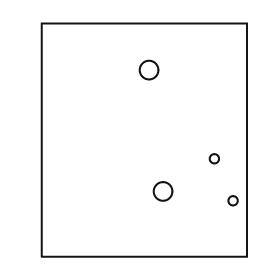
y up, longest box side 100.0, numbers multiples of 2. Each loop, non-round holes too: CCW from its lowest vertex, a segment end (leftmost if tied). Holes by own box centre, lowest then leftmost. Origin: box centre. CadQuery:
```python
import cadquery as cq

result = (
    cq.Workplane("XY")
    .moveTo(-44.0, -50.0)
    .lineTo(44.0, -50.0)
    .lineTo(44.0, 50.0)
    .lineTo(-44.0, 50.0)
    .close()
    .moveTo(38.0, -26.0)
    .circle(2.0)
    .moveTo(8.0, -22.0)
    .circle(4.0)
    .moveTo(30.0, -8.0)
    .circle(2.0)
    .moveTo(2.0, 30.0)
    .circle(4.0)
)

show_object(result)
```